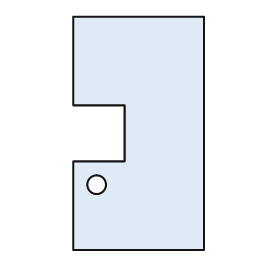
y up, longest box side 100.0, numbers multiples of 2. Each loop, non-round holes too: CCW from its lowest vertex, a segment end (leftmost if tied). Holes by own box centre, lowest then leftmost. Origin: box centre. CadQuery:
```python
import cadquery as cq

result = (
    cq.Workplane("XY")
    .moveTo(-28.0, -50.0)
    .lineTo(28.0, -50.0)
    .lineTo(28.0, 50.0)
    .lineTo(-28.0, 50.0)
    .lineTo(-28.0, 12.0)
    .lineTo(-6.0, 12.0)
    .lineTo(-6.0, -12.0)
    .lineTo(-28.0, -12.0)
    .close()
    .moveTo(-18.0, -22.0)
    .circle(4.0)
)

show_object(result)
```